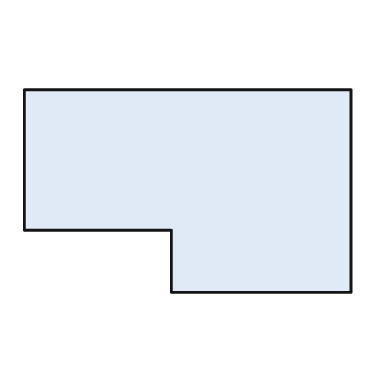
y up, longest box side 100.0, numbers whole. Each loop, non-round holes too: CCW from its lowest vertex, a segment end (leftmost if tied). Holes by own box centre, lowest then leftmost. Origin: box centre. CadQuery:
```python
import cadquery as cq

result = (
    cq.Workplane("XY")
    .moveTo(-5.0, -31.0)
    .lineTo(50.0, -31.0)
    .lineTo(50.0, 31.0)
    .lineTo(-50.0, 31.0)
    .lineTo(-50.0, -12.0)
    .lineTo(-5.0, -12.0)
    .close()
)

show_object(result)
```